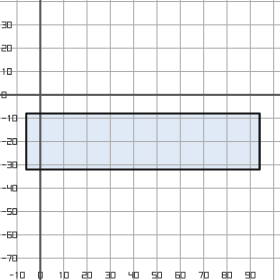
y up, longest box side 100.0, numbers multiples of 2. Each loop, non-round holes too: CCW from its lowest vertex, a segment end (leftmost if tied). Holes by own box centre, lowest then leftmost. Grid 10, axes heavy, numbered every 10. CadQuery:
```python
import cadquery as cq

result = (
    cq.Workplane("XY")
    .moveTo(-6.0, -32.0)
    .lineTo(94.0, -32.0)
    .lineTo(94.0, -8.0)
    .lineTo(-6.0, -8.0)
    .close()
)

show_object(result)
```